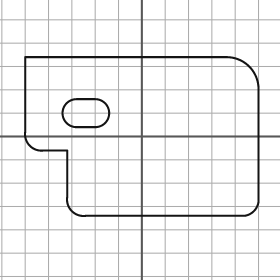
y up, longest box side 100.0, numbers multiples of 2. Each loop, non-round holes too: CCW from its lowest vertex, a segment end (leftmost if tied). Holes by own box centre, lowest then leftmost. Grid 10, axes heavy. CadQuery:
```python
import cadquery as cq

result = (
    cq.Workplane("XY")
    .moveTo(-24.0, -34.0)
    .lineTo(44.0, -34.0)
    .threePointArc((48.0, -32.0), (50.0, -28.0))
    .lineTo(50.0, 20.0)
    .threePointArc((46.0, 30.0), (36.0, 34.0))
    .lineTo(-50.0, 34.0)
    .lineTo(-50.0, 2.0)
    .threePointArc((-48.0, -4.0), (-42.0, -6.0))
    .lineTo(-32.0, -6.0)
    .lineTo(-32.0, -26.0)
    .threePointArc((-30.0, -32.0), (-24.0, -34.0))
    .close()
    .moveTo(-28.0, 4.0)
    .lineTo(-20.0, 4.0)
    .threePointArc((-14.0, 10.0), (-20.0, 16.0))
    .lineTo(-28.0, 16.0)
    .threePointArc((-34.0, 10.0), (-28.0, 4.0))
    .close()
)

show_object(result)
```